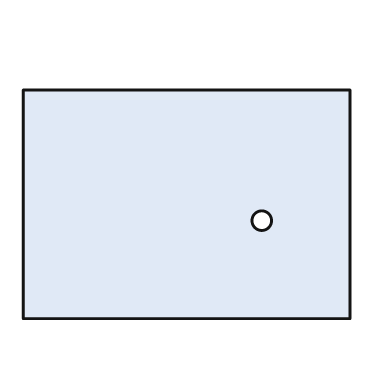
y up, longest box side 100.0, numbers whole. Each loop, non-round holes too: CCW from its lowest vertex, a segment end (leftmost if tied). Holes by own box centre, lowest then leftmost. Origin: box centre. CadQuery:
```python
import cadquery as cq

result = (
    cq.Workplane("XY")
    .moveTo(-50.0, -35.0)
    .lineTo(50.0, -35.0)
    .lineTo(50.0, 35.0)
    .lineTo(-50.0, 35.0)
    .close()
    .moveTo(23.0, -5.0)
    .circle(3.0)
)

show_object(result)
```